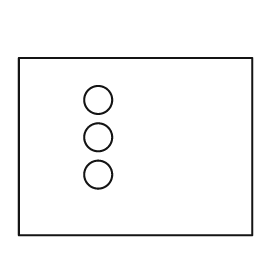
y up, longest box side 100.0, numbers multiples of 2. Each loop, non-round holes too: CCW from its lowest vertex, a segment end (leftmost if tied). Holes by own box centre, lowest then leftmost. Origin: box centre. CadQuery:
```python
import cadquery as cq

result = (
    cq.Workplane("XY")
    .moveTo(-50.0, -38.0)
    .lineTo(50.0, -38.0)
    .lineTo(50.0, 38.0)
    .lineTo(-50.0, 38.0)
    .close()
    .moveTo(-16.0, -12.0)
    .circle(6.0)
    .moveTo(-16.0, 4.0)
    .circle(6.0)
    .moveTo(-16.0, 20.0)
    .circle(6.0)
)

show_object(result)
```